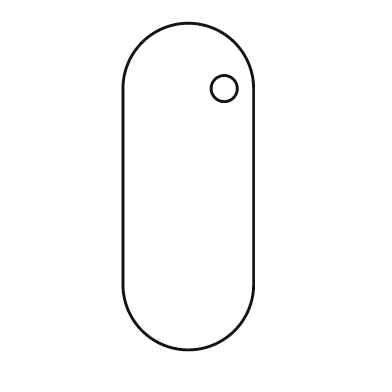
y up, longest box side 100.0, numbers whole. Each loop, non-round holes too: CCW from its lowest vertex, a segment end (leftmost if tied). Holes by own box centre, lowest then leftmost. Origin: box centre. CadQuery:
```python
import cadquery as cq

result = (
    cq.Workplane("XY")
    .moveTo(-20.0, -30.0)
    .threePointArc((0.0, -50.0), (20.0, -30.0))
    .lineTo(20.0, 30.0)
    .threePointArc((0.0, 50.0), (-20.0, 30.0))
    .close()
    .moveTo(11.0, 30.0)
    .circle(4.0)
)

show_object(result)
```